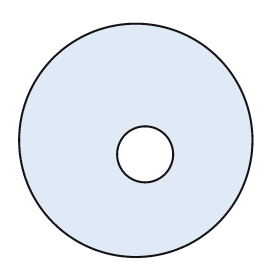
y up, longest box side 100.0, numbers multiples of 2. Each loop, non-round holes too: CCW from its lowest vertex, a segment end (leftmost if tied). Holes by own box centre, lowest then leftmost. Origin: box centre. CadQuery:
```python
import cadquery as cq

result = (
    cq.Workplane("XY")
    .moveTo(0.0, 0.0)
    .circle(50.0)
    .moveTo(4.0, -6.0)
    .circle(12.0)
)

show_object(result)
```